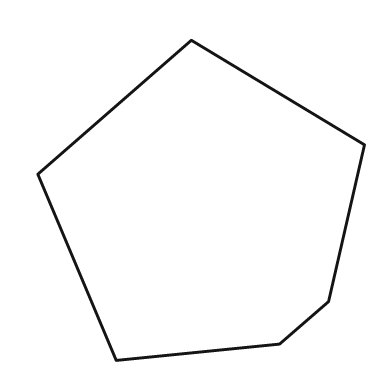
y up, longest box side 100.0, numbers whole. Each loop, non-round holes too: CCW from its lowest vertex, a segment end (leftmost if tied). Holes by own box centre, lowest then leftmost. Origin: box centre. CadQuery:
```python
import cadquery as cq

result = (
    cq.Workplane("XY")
    .moveTo(-26.0, -49.0)
    .lineTo(24.0, -44.0)
    .lineTo(39.0, -31.0)
    .lineTo(50.0, 17.0)
    .lineTo(-3.0, 49.0)
    .lineTo(-50.0, 8.0)
    .close()
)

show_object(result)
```